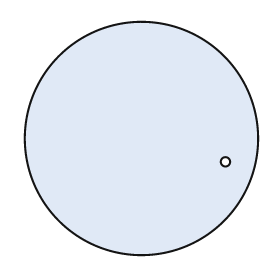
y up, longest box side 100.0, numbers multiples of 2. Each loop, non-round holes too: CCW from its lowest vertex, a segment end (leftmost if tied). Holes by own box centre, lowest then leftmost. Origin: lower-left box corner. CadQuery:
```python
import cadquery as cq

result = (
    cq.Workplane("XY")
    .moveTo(50.0, 50.0)
    .circle(50.0)
    .moveTo(86.0, 40.0)
    .circle(2.0)
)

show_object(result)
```